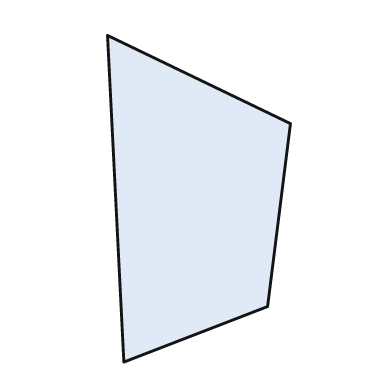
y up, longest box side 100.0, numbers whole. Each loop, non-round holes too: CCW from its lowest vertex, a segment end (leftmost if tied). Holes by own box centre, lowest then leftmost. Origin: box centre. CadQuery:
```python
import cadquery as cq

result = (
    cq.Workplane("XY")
    .moveTo(-23.0, -50.0)
    .lineTo(21.0, -33.0)
    .lineTo(28.0, 23.0)
    .lineTo(-28.0, 50.0)
    .close()
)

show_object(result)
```